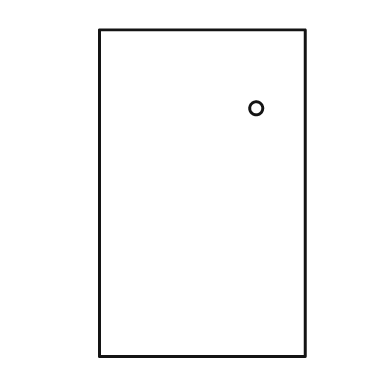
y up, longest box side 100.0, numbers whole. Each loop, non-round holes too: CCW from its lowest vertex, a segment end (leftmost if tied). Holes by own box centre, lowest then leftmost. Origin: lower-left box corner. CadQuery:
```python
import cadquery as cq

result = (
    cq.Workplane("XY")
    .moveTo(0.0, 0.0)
    .lineTo(63.0, 0.0)
    .lineTo(63.0, 100.0)
    .lineTo(0.0, 100.0)
    .close()
    .moveTo(48.0, 76.0)
    .circle(2.0)
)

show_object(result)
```